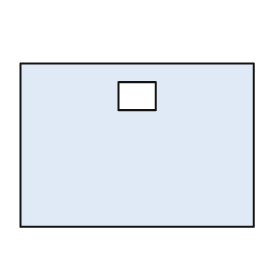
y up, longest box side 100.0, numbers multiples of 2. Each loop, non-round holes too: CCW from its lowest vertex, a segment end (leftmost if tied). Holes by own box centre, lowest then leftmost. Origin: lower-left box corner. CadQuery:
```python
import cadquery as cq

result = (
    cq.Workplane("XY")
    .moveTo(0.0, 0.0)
    .lineTo(100.0, 0.0)
    .lineTo(100.0, 70.0)
    .lineTo(0.0, 70.0)
    .close()
    .moveTo(42.0, 50.0)
    .lineTo(58.0, 50.0)
    .lineTo(58.0, 62.0)
    .lineTo(42.0, 62.0)
    .close()
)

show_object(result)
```